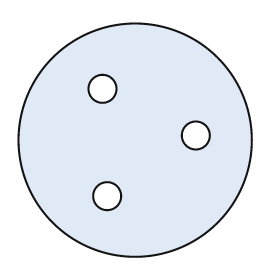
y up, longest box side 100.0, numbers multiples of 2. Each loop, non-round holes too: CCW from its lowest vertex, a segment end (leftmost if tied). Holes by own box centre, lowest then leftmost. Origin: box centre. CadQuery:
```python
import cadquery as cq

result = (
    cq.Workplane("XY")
    .moveTo(0.0, 0.0)
    .circle(50.0)
    .moveTo(-12.0, -24.0)
    .circle(6.0)
    .moveTo(26.0, 2.0)
    .circle(6.0)
    .moveTo(-14.0, 22.0)
    .circle(6.0)
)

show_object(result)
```